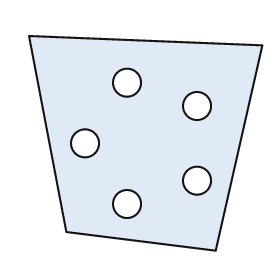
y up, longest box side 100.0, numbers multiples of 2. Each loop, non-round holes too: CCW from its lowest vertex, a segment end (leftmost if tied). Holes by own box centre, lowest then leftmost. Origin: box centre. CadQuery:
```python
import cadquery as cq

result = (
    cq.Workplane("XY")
    .moveTo(30.0, -46.0)
    .lineTo(50.0, 42.0)
    .lineTo(-50.0, 46.0)
    .lineTo(-34.0, -38.0)
    .close()
    .moveTo(-8.0, -26.0)
    .circle(6.0)
    .moveTo(22.0, -16.0)
    .circle(6.0)
    .moveTo(-26.0, 0.0)
    .circle(6.0)
    .moveTo(22.0, 16.0)
    .circle(6.0)
    .moveTo(-8.0, 26.0)
    .circle(6.0)
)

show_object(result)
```